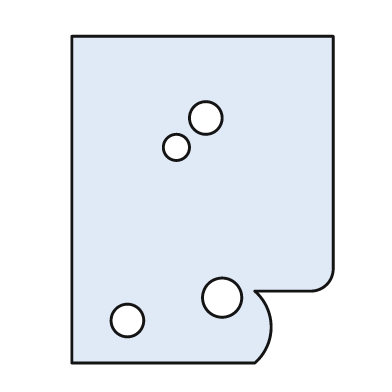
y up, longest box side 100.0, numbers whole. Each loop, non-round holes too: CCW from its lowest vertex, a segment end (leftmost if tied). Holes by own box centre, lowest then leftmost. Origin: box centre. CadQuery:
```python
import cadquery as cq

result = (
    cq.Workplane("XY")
    .moveTo(-40.0, -50.0)
    .lineTo(16.0, -50.0)
    .threePointArc((21.0, -39.0), (16.0, -28.0))
    .lineTo(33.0, -28.0)
    .threePointArc((38.0, -26.0), (40.0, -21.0))
    .lineTo(40.0, 50.0)
    .lineTo(-40.0, 50.0)
    .close()
    .moveTo(-23.0, -37.0)
    .circle(5.0)
    .moveTo(6.0, -30.0)
    .circle(6.0)
    .moveTo(-8.0, 16.0)
    .circle(4.0)
    .moveTo(1.0, 25.0)
    .circle(5.0)
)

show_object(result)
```